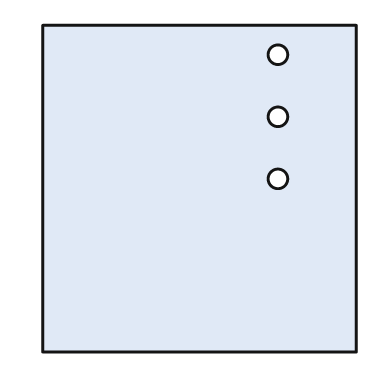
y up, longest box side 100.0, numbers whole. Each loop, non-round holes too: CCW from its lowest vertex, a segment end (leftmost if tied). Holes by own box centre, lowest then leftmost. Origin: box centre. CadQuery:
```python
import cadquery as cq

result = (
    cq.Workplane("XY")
    .moveTo(-48.0, -50.0)
    .lineTo(48.0, -50.0)
    .lineTo(48.0, 50.0)
    .lineTo(-48.0, 50.0)
    .close()
    .moveTo(24.0, 3.0)
    .circle(3.0)
    .moveTo(24.0, 22.0)
    .circle(3.0)
    .moveTo(24.0, 41.0)
    .circle(3.0)
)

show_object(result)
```